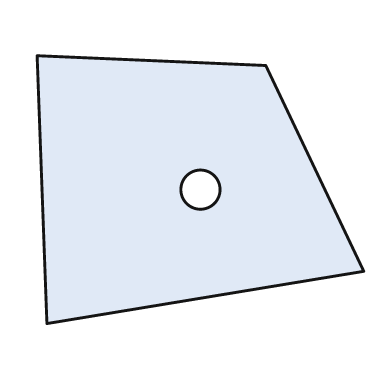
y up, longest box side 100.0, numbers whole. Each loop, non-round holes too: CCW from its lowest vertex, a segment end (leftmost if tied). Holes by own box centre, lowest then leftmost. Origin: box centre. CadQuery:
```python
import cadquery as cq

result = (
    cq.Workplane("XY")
    .moveTo(-47.0, -41.0)
    .lineTo(50.0, -25.0)
    .lineTo(20.0, 38.0)
    .lineTo(-50.0, 41.0)
    .close()
    .moveTo(0.0, 0.0)
    .circle(6.0)
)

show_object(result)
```